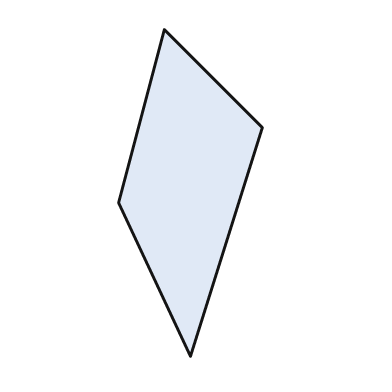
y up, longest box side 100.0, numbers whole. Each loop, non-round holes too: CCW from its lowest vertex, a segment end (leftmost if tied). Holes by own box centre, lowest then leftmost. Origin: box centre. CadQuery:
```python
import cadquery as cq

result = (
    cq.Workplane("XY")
    .moveTo(0.0, -50.0)
    .lineTo(22.0, 20.0)
    .lineTo(-8.0, 50.0)
    .lineTo(-22.0, -3.0)
    .close()
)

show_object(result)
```